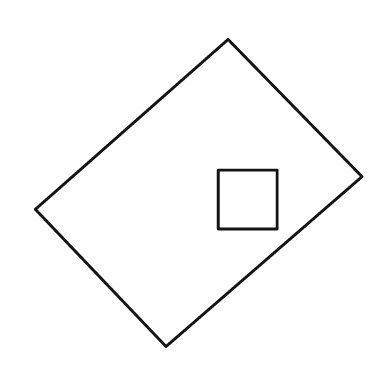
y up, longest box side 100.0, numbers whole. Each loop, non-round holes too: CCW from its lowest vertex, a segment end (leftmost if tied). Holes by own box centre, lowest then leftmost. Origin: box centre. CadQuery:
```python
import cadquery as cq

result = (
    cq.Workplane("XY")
    .moveTo(-10.0, -47.0)
    .lineTo(50.0, 5.0)
    .lineTo(9.0, 47.0)
    .lineTo(-50.0, -5.0)
    .close()
    .moveTo(6.0, -11.0)
    .lineTo(24.0, -11.0)
    .lineTo(24.0, 7.0)
    .lineTo(6.0, 7.0)
    .close()
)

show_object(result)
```